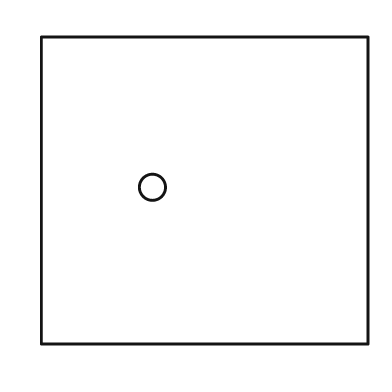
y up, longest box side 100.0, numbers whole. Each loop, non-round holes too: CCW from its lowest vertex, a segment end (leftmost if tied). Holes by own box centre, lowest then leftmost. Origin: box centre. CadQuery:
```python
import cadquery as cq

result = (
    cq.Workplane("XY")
    .moveTo(-50.0, -47.0)
    .lineTo(50.0, -47.0)
    .lineTo(50.0, 47.0)
    .lineTo(-50.0, 47.0)
    .close()
    .moveTo(-16.0, 1.0)
    .circle(4.0)
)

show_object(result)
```